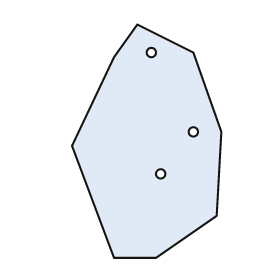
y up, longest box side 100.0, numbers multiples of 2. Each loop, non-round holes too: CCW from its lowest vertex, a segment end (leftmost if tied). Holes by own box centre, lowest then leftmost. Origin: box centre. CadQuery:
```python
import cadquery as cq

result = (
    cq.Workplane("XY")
    .moveTo(-14.0, -50.0)
    .lineTo(4.0, -50.0)
    .lineTo(30.0, -32.0)
    .lineTo(32.0, 4.0)
    .lineTo(20.0, 38.0)
    .lineTo(-4.0, 50.0)
    .lineTo(-14.0, 36.0)
    .lineTo(-32.0, -2.0)
    .close()
    .moveTo(6.0, -14.0)
    .circle(2.0)
    .moveTo(20.0, 4.0)
    .circle(2.0)
    .moveTo(2.0, 38.0)
    .circle(2.0)
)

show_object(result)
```